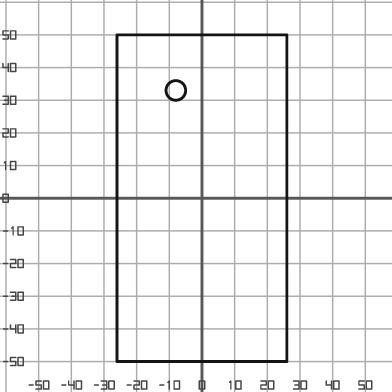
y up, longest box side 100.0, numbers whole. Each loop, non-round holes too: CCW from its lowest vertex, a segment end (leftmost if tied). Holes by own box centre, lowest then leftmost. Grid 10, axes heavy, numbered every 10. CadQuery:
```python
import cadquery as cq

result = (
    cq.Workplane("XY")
    .moveTo(-26.0, -50.0)
    .lineTo(26.0, -50.0)
    .lineTo(26.0, 50.0)
    .lineTo(-26.0, 50.0)
    .close()
    .moveTo(-8.0, 33.0)
    .circle(3.0)
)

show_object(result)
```